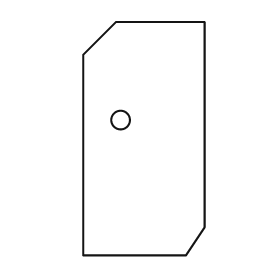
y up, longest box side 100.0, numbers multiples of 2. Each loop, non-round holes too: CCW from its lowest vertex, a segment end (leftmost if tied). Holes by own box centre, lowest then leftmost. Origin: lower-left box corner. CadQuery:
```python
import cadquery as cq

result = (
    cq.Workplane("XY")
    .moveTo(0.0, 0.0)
    .lineTo(44.0, 0.0)
    .lineTo(52.0, 12.0)
    .lineTo(52.0, 100.0)
    .lineTo(14.0, 100.0)
    .lineTo(0.0, 86.0)
    .close()
    .moveTo(16.0, 58.0)
    .circle(4.0)
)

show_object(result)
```